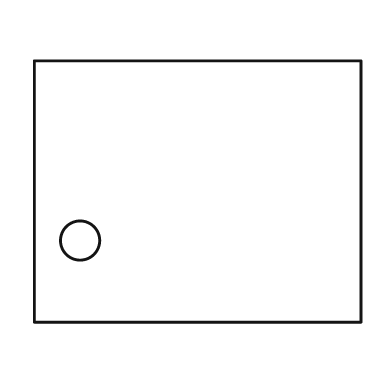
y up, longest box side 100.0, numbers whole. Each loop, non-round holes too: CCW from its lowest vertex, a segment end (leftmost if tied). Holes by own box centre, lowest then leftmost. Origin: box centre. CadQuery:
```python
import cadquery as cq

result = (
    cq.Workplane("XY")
    .moveTo(-50.0, -40.0)
    .lineTo(50.0, -40.0)
    .lineTo(50.0, 40.0)
    .lineTo(-50.0, 40.0)
    .close()
    .moveTo(-36.0, -15.0)
    .circle(6.0)
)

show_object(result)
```